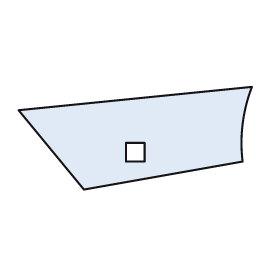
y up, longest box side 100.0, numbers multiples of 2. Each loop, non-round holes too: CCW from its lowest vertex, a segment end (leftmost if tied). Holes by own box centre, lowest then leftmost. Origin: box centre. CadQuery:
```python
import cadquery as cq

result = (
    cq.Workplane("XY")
    .moveTo(-22.0, -22.0)
    .lineTo(46.0, -10.0)
    .threePointArc((46.0, 6.0), (50.0, 22.0))
    .lineTo(-50.0, 12.0)
    .close()
    .moveTo(-4.0, -10.0)
    .lineTo(4.0, -10.0)
    .lineTo(4.0, -2.0)
    .lineTo(-4.0, -2.0)
    .close()
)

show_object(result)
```